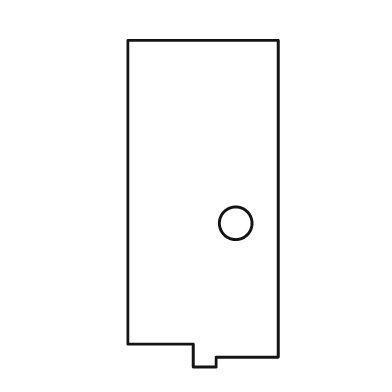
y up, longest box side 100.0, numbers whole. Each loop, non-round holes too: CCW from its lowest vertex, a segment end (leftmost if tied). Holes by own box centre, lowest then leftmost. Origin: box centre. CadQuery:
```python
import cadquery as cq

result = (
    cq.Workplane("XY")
    .moveTo(-3.0, -50.0)
    .lineTo(4.0, -50.0)
    .lineTo(4.0, -47.0)
    .lineTo(23.0, -47.0)
    .lineTo(23.0, 50.0)
    .lineTo(-23.0, 50.0)
    .lineTo(-23.0, -43.0)
    .lineTo(-3.0, -43.0)
    .close()
    .moveTo(10.0, -6.0)
    .circle(5.0)
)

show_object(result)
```